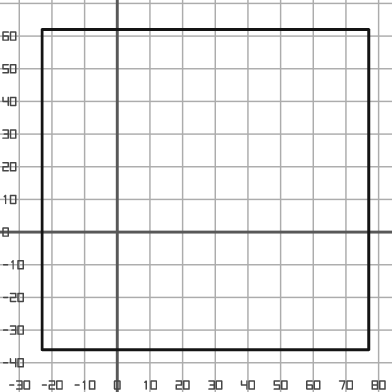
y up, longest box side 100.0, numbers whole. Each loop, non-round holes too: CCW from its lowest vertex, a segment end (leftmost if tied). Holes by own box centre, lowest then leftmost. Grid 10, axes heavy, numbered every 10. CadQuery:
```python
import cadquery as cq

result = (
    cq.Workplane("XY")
    .moveTo(-23.0, -36.0)
    .lineTo(77.0, -36.0)
    .lineTo(77.0, 62.0)
    .lineTo(-23.0, 62.0)
    .close()
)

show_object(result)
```